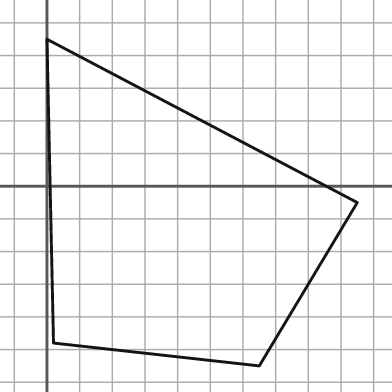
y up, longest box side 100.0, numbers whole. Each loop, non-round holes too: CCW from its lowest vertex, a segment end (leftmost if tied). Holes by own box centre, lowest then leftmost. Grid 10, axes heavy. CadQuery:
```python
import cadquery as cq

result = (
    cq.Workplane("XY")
    .moveTo(65.0, -55.0)
    .lineTo(95.0, -5.0)
    .lineTo(0.0, 45.0)
    .lineTo(2.0, -48.0)
    .close()
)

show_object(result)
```